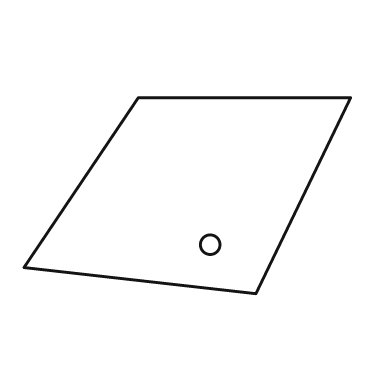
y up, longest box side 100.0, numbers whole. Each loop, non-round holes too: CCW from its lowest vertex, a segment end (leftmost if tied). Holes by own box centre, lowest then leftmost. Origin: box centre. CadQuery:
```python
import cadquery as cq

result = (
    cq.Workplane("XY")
    .moveTo(21.0, -30.0)
    .lineTo(50.0, 30.0)
    .lineTo(-15.0, 30.0)
    .lineTo(-50.0, -22.0)
    .close()
    .moveTo(7.0, -15.0)
    .circle(3.0)
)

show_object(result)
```